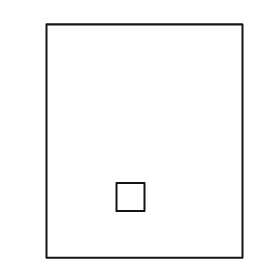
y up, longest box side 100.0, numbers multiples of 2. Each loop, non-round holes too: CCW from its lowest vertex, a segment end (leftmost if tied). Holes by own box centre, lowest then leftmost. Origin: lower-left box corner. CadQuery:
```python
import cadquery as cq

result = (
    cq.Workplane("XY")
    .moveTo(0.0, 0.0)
    .lineTo(84.0, 0.0)
    .lineTo(84.0, 100.0)
    .lineTo(0.0, 100.0)
    .close()
    .moveTo(30.0, 20.0)
    .lineTo(42.0, 20.0)
    .lineTo(42.0, 32.0)
    .lineTo(30.0, 32.0)
    .close()
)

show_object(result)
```